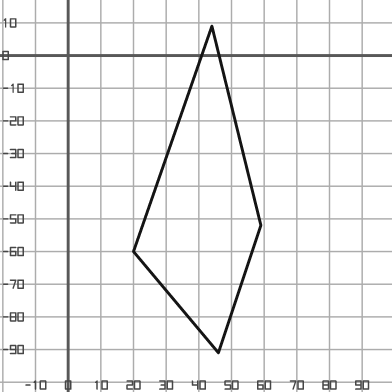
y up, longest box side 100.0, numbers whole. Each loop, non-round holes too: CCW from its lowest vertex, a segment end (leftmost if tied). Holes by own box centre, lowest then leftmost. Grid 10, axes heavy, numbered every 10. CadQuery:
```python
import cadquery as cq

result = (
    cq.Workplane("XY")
    .moveTo(46.0, -91.0)
    .lineTo(59.0, -52.0)
    .lineTo(44.0, 9.0)
    .lineTo(20.0, -60.0)
    .close()
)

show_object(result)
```